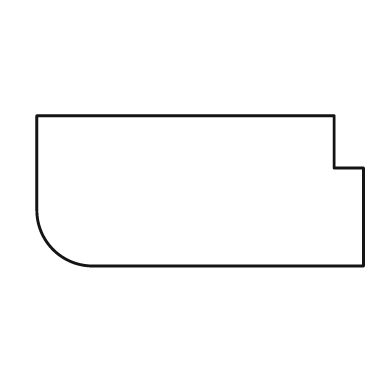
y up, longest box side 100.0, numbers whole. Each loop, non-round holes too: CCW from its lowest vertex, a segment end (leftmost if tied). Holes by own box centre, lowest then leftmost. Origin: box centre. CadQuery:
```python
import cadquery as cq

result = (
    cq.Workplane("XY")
    .moveTo(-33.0, -23.0)
    .lineTo(50.0, -23.0)
    .lineTo(50.0, 7.0)
    .lineTo(41.0, 7.0)
    .lineTo(41.0, 23.0)
    .lineTo(-50.0, 23.0)
    .lineTo(-50.0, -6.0)
    .threePointArc((-45.0, -18.0), (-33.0, -23.0))
    .close()
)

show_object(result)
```